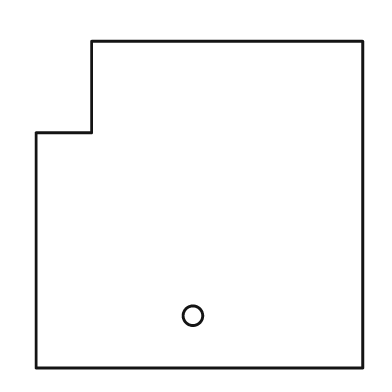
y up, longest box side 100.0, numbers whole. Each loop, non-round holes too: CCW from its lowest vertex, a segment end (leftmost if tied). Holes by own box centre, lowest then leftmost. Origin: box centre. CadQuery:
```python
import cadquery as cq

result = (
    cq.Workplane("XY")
    .moveTo(-50.0, -50.0)
    .lineTo(50.0, -50.0)
    .lineTo(50.0, 50.0)
    .lineTo(-33.0, 50.0)
    .lineTo(-33.0, 22.0)
    .lineTo(-50.0, 22.0)
    .close()
    .moveTo(-2.0, -34.0)
    .circle(3.0)
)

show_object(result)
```